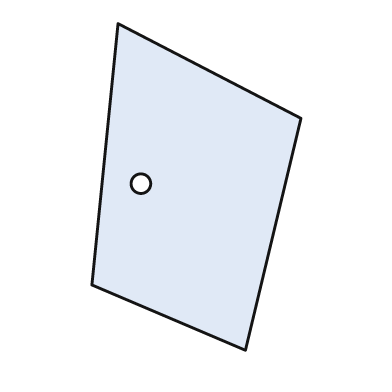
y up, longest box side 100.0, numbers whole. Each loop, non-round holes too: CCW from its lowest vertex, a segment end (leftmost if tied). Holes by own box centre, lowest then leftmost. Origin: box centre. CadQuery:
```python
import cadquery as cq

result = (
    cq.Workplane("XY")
    .moveTo(15.0, -50.0)
    .lineTo(32.0, 21.0)
    .lineTo(-24.0, 50.0)
    .lineTo(-32.0, -30.0)
    .close()
    .moveTo(-17.0, 1.0)
    .circle(3.0)
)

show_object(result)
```